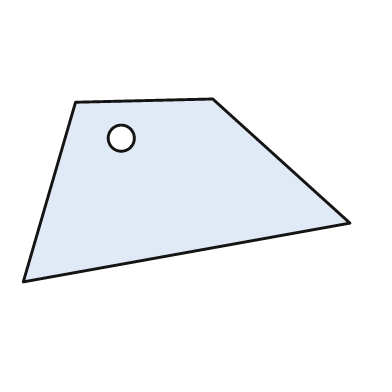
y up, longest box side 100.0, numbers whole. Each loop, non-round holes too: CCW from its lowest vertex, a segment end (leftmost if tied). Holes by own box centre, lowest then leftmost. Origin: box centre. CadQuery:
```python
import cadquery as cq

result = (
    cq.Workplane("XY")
    .moveTo(-50.0, -28.0)
    .lineTo(50.0, -10.0)
    .lineTo(8.0, 28.0)
    .lineTo(-34.0, 27.0)
    .close()
    .moveTo(-20.0, 16.0)
    .circle(4.0)
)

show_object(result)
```